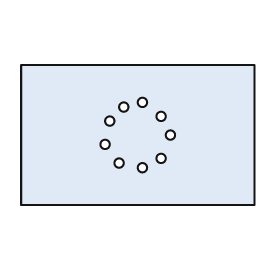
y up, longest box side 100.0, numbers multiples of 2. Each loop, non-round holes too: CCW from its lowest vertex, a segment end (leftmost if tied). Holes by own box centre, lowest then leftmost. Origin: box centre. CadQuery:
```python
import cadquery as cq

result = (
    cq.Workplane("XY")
    .moveTo(-50.0, -30.0)
    .lineTo(50.0, -30.0)
    .lineTo(50.0, 30.0)
    .lineTo(-50.0, 30.0)
    .close()
    .moveTo(2.0, -14.0)
    .circle(2.0)
    .moveTo(-8.0, -12.0)
    .circle(2.0)
    .moveTo(10.0, -10.0)
    .circle(2.0)
    .moveTo(-14.0, -4.0)
    .circle(2.0)
    .moveTo(14.0, 0.0)
    .circle(2.0)
    .moveTo(-12.0, 6.0)
    .circle(2.0)
    .moveTo(10.0, 8.0)
    .circle(2.0)
    .moveTo(-6.0, 12.0)
    .circle(2.0)
    .moveTo(2.0, 14.0)
    .circle(2.0)
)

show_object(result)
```